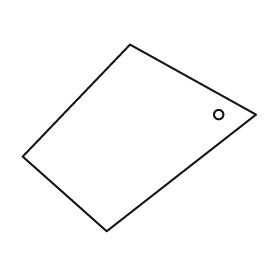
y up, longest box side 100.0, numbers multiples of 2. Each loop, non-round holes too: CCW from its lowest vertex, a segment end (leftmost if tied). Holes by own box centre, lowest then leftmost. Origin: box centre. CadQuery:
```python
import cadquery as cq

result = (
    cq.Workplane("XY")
    .moveTo(-14.0, -40.0)
    .lineTo(50.0, 10.0)
    .lineTo(-4.0, 40.0)
    .lineTo(-50.0, -8.0)
    .close()
    .moveTo(34.0, 10.0)
    .circle(2.0)
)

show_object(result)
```